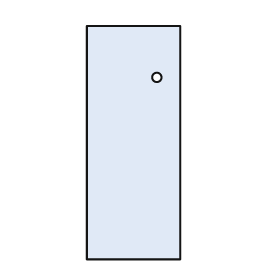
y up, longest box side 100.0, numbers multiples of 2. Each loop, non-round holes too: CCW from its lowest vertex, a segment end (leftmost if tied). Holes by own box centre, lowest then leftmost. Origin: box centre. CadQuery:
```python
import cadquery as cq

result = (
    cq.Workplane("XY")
    .moveTo(-20.0, -50.0)
    .lineTo(20.0, -50.0)
    .lineTo(20.0, 50.0)
    .lineTo(-20.0, 50.0)
    .close()
    .moveTo(10.0, 28.0)
    .circle(2.0)
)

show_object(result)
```